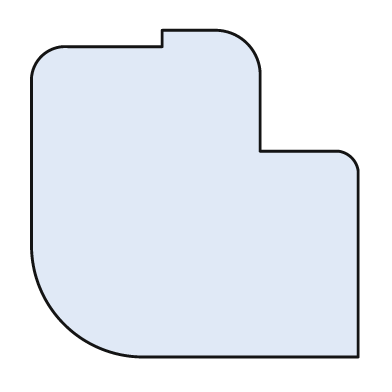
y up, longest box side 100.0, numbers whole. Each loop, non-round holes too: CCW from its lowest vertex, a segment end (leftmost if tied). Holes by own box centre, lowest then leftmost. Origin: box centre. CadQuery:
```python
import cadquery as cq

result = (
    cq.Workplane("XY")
    .moveTo(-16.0, -50.0)
    .lineTo(50.0, -50.0)
    .lineTo(50.0, 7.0)
    .threePointArc((48.0, 11.0), (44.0, 13.0))
    .lineTo(20.0, 13.0)
    .lineTo(20.0, 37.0)
    .threePointArc((16.0, 46.0), (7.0, 50.0))
    .lineTo(-10.0, 50.0)
    .lineTo(-10.0, 45.0)
    .lineTo(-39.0, 45.0)
    .threePointArc((-47.0, 42.0), (-50.0, 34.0))
    .lineTo(-50.0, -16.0)
    .threePointArc((-40.0, -40.0), (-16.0, -50.0))
    .close()
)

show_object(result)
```